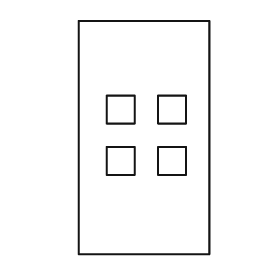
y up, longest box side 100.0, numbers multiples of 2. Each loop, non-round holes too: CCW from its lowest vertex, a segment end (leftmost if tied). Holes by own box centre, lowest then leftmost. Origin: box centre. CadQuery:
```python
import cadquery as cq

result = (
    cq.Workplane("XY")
    .moveTo(-28.0, -50.0)
    .lineTo(28.0, -50.0)
    .lineTo(28.0, 50.0)
    .lineTo(-28.0, 50.0)
    .close()
    .moveTo(-16.0, -16.0)
    .lineTo(-4.0, -16.0)
    .lineTo(-4.0, -4.0)
    .lineTo(-16.0, -4.0)
    .close()
    .moveTo(6.0, -16.0)
    .lineTo(18.0, -16.0)
    .lineTo(18.0, -4.0)
    .lineTo(6.0, -4.0)
    .close()
    .moveTo(-16.0, 6.0)
    .lineTo(-4.0, 6.0)
    .lineTo(-4.0, 18.0)
    .lineTo(-16.0, 18.0)
    .close()
    .moveTo(6.0, 6.0)
    .lineTo(18.0, 6.0)
    .lineTo(18.0, 18.0)
    .lineTo(6.0, 18.0)
    .close()
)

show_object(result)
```